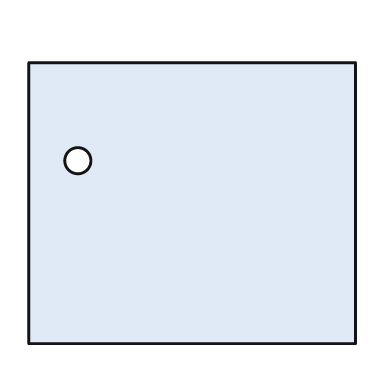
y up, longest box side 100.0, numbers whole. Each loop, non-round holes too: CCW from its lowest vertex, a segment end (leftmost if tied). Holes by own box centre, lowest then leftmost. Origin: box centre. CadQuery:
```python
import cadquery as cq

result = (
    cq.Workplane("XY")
    .moveTo(-50.0, -43.0)
    .lineTo(50.0, -43.0)
    .lineTo(50.0, 43.0)
    .lineTo(-50.0, 43.0)
    .close()
    .moveTo(-35.0, 13.0)
    .circle(4.0)
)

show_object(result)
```